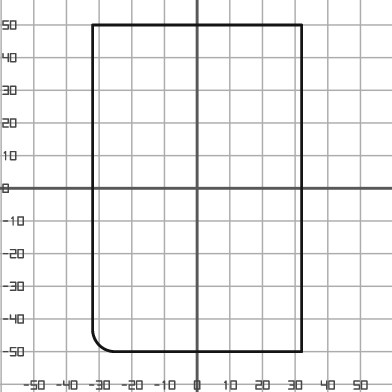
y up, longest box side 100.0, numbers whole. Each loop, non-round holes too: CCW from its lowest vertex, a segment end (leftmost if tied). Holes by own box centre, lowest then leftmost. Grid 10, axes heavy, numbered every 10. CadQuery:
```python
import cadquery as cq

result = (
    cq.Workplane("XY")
    .moveTo(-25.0, -50.0)
    .lineTo(32.0, -50.0)
    .lineTo(32.0, 50.0)
    .lineTo(-32.0, 50.0)
    .lineTo(-32.0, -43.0)
    .threePointArc((-30.0, -48.0), (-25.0, -50.0))
    .close()
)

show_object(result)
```